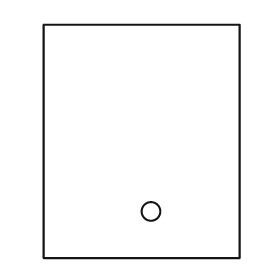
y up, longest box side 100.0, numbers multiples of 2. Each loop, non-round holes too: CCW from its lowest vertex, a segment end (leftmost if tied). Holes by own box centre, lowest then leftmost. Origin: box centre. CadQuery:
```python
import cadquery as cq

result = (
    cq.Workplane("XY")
    .moveTo(-42.0, -50.0)
    .lineTo(42.0, -50.0)
    .lineTo(42.0, 50.0)
    .lineTo(-42.0, 50.0)
    .close()
    .moveTo(4.0, -30.0)
    .circle(4.0)
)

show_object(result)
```